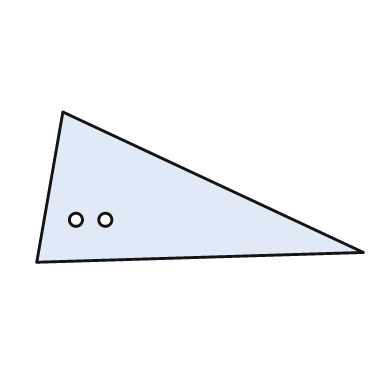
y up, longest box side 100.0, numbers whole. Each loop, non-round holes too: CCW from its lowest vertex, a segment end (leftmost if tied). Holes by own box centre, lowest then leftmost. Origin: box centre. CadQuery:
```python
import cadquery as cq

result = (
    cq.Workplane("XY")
    .moveTo(-50.0, -23.0)
    .lineTo(50.0, -20.0)
    .lineTo(-42.0, 23.0)
    .close()
    .moveTo(-38.0, -10.0)
    .circle(2.0)
    .moveTo(-29.0, -10.0)
    .circle(2.0)
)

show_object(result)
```